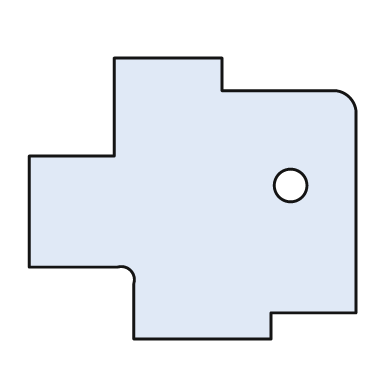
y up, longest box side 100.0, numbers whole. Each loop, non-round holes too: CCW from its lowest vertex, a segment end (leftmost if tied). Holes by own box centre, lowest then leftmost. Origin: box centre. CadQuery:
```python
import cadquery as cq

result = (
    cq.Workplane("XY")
    .moveTo(-18.0, -43.0)
    .lineTo(24.0, -43.0)
    .lineTo(24.0, -35.0)
    .lineTo(50.0, -35.0)
    .lineTo(50.0, 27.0)
    .threePointArc((48.0, 31.0), (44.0, 33.0))
    .lineTo(9.0, 33.0)
    .lineTo(9.0, 43.0)
    .lineTo(-24.0, 43.0)
    .lineTo(-24.0, 13.0)
    .lineTo(-50.0, 13.0)
    .lineTo(-50.0, -21.0)
    .lineTo(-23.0, -21.0)
    .threePointArc((-19.0, -22.0), (-18.0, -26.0))
    .close()
    .moveTo(30.0, 4.0)
    .circle(5.0)
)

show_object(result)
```